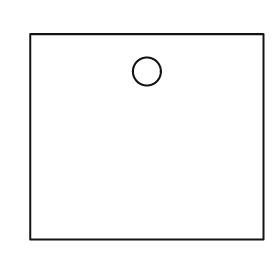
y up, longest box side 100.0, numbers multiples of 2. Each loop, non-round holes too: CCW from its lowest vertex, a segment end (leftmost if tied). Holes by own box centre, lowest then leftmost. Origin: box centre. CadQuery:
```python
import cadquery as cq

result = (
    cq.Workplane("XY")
    .moveTo(-50.0, -44.0)
    .lineTo(50.0, -44.0)
    .lineTo(50.0, 44.0)
    .lineTo(-50.0, 44.0)
    .close()
    .moveTo(0.0, 28.0)
    .circle(6.0)
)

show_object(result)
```